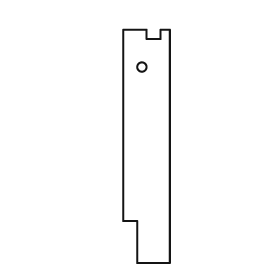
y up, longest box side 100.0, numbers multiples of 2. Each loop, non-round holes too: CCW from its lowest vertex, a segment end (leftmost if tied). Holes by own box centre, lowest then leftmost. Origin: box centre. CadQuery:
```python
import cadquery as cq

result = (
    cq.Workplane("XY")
    .moveTo(-4.0, -50.0)
    .lineTo(10.0, -50.0)
    .lineTo(10.0, 50.0)
    .lineTo(6.0, 50.0)
    .lineTo(6.0, 46.0)
    .lineTo(0.0, 46.0)
    .lineTo(0.0, 50.0)
    .lineTo(-10.0, 50.0)
    .lineTo(-10.0, -32.0)
    .lineTo(-4.0, -32.0)
    .close()
    .moveTo(-2.0, 34.0)
    .circle(2.0)
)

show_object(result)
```